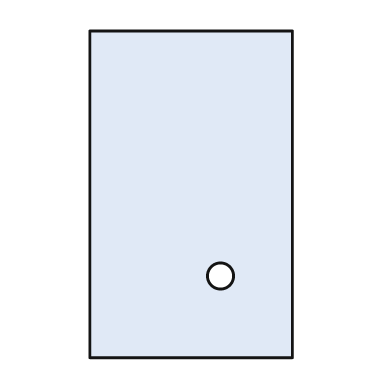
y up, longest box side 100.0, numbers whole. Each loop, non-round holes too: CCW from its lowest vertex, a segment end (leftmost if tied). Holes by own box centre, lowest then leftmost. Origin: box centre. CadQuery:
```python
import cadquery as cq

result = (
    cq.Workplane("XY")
    .moveTo(-31.0, -50.0)
    .lineTo(31.0, -50.0)
    .lineTo(31.0, 50.0)
    .lineTo(-31.0, 50.0)
    .close()
    .moveTo(9.0, -25.0)
    .circle(4.0)
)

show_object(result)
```